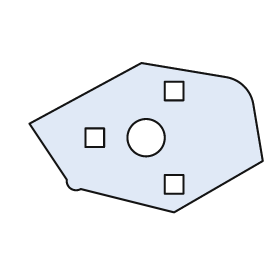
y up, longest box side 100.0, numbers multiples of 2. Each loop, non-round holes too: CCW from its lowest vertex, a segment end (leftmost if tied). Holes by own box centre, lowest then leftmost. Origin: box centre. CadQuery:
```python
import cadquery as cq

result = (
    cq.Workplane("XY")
    .moveTo(12.0, -32.0)
    .lineTo(50.0, -10.0)
    .lineTo(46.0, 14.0)
    .threePointArc((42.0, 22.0), (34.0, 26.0))
    .lineTo(-2.0, 32.0)
    .lineTo(-50.0, 6.0)
    .lineTo(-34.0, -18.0)
    .threePointArc((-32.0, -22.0), (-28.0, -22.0))
    .close()
    .moveTo(8.0, -24.0)
    .lineTo(16.0, -24.0)
    .lineTo(16.0, -16.0)
    .lineTo(8.0, -16.0)
    .close()
    .moveTo(-26.0, -4.0)
    .lineTo(-18.0, -4.0)
    .lineTo(-18.0, 4.0)
    .lineTo(-26.0, 4.0)
    .close()
    .moveTo(0.0, 0.0)
    .circle(8.0)
    .moveTo(8.0, 16.0)
    .lineTo(16.0, 16.0)
    .lineTo(16.0, 24.0)
    .lineTo(8.0, 24.0)
    .close()
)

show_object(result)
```